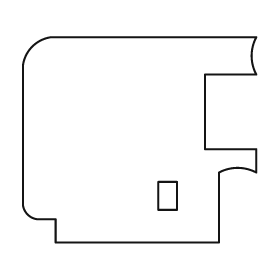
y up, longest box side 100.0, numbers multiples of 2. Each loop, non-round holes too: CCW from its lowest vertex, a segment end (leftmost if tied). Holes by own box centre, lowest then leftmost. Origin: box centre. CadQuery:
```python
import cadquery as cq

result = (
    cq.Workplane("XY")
    .moveTo(-36.0, -44.0)
    .lineTo(34.0, -44.0)
    .lineTo(34.0, -14.0)
    .threePointArc((42.0, -12.0), (50.0, -14.0))
    .lineTo(50.0, -4.0)
    .lineTo(28.0, -4.0)
    .lineTo(28.0, 28.0)
    .lineTo(50.0, 28.0)
    .threePointArc((48.0, 36.0), (50.0, 44.0))
    .lineTo(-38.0, 44.0)
    .threePointArc((-46.0, 40.0), (-50.0, 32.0))
    .lineTo(-50.0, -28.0)
    .threePointArc((-48.0, -32.0), (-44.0, -34.0))
    .lineTo(-36.0, -34.0)
    .close()
    .moveTo(8.0, -30.0)
    .lineTo(16.0, -30.0)
    .lineTo(16.0, -18.0)
    .lineTo(8.0, -18.0)
    .close()
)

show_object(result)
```